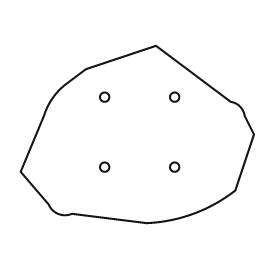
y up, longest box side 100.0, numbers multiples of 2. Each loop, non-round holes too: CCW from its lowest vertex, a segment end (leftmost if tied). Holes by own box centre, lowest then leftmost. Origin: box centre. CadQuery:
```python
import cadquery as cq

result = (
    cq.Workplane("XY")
    .moveTo(4.0, -38.0)
    .threePointArc((24.0, -34.0), (42.0, -24.0))
    .lineTo(50.0, 0.0)
    .lineTo(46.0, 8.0)
    .threePointArc((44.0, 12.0), (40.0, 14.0))
    .lineTo(8.0, 38.0)
    .lineTo(-22.0, 28.0)
    .lineTo(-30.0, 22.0)
    .threePointArc((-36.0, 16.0), (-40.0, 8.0))
    .lineTo(-50.0, -16.0)
    .lineTo(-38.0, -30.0)
    .threePointArc((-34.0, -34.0), (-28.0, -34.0))
    .close()
    .moveTo(-14.0, -14.0)
    .circle(2.0)
    .moveTo(16.0, -14.0)
    .circle(2.0)
    .moveTo(-14.0, 16.0)
    .circle(2.0)
    .moveTo(16.0, 16.0)
    .circle(2.0)
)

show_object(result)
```